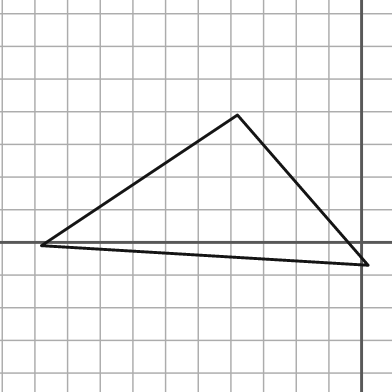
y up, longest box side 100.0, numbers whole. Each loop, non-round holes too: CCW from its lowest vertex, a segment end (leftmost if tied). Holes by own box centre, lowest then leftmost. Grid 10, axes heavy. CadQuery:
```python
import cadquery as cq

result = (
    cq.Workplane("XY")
    .moveTo(2.0, -7.0)
    .lineTo(-38.0, 39.0)
    .lineTo(-98.0, -1.0)
    .close()
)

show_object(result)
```